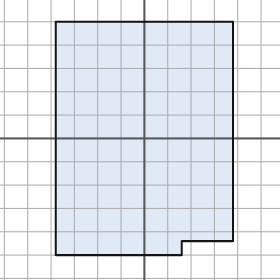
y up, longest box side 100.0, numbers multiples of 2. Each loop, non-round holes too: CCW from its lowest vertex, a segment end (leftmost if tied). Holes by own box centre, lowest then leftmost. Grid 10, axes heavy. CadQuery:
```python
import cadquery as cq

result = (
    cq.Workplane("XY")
    .moveTo(-38.0, -50.0)
    .lineTo(16.0, -50.0)
    .lineTo(16.0, -44.0)
    .lineTo(38.0, -44.0)
    .lineTo(38.0, 50.0)
    .lineTo(-38.0, 50.0)
    .close()
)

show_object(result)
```